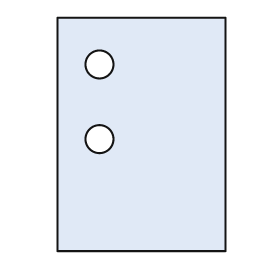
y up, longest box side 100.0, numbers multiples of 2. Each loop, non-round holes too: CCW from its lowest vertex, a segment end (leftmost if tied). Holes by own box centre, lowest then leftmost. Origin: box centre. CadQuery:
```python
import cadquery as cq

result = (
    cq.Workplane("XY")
    .moveTo(-36.0, -50.0)
    .lineTo(36.0, -50.0)
    .lineTo(36.0, 50.0)
    .lineTo(-36.0, 50.0)
    .close()
    .moveTo(-18.0, -2.0)
    .circle(6.0)
    .moveTo(-18.0, 30.0)
    .circle(6.0)
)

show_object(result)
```